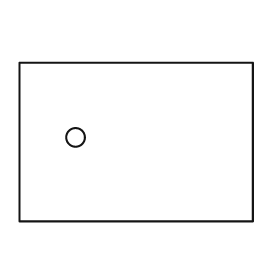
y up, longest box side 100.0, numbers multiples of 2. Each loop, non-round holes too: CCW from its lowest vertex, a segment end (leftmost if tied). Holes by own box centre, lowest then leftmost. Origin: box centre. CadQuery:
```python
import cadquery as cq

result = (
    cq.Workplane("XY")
    .moveTo(-50.0, -34.0)
    .lineTo(50.0, -34.0)
    .lineTo(50.0, 34.0)
    .lineTo(-50.0, 34.0)
    .close()
    .moveTo(-26.0, 2.0)
    .circle(4.0)
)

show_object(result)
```